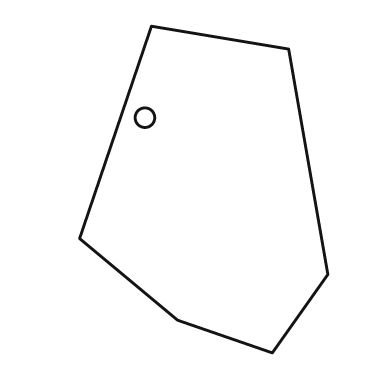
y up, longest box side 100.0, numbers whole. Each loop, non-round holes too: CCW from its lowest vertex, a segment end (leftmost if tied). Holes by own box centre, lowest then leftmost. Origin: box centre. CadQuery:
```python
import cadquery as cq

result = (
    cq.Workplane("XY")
    .moveTo(21.0, -50.0)
    .lineTo(38.0, -26.0)
    .lineTo(26.0, 43.0)
    .lineTo(-16.0, 50.0)
    .lineTo(-38.0, -15.0)
    .lineTo(-8.0, -40.0)
    .close()
    .moveTo(-18.0, 22.0)
    .circle(3.0)
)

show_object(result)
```